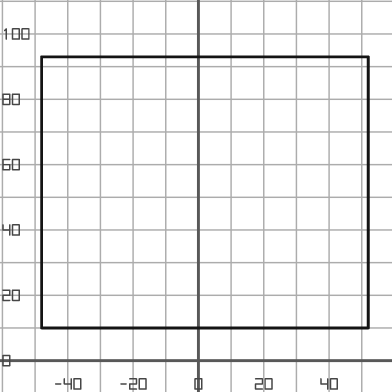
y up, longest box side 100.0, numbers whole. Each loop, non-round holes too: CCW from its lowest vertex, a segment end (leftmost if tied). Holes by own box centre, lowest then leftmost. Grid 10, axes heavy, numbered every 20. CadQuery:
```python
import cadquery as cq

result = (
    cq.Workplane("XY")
    .moveTo(-48.0, 10.0)
    .lineTo(52.0, 10.0)
    .lineTo(52.0, 93.0)
    .lineTo(-48.0, 93.0)
    .close()
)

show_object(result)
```